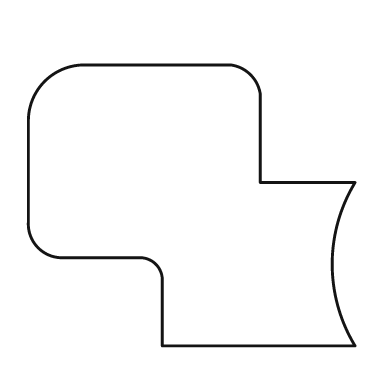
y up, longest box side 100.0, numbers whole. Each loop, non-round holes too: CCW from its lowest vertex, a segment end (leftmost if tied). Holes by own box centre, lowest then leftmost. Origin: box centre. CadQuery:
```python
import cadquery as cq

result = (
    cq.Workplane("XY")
    .moveTo(-9.0, -43.0)
    .lineTo(50.0, -43.0)
    .threePointArc((43.0, -18.0), (50.0, 7.0))
    .lineTo(21.0, 7.0)
    .lineTo(21.0, 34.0)
    .threePointArc((18.0, 40.0), (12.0, 43.0))
    .lineTo(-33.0, 43.0)
    .threePointArc((-45.0, 38.0), (-50.0, 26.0))
    .lineTo(-50.0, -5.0)
    .threePointArc((-47.0, -13.0), (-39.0, -16.0))
    .lineTo(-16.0, -16.0)
    .threePointArc((-11.0, -18.0), (-9.0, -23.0))
    .close()
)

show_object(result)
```